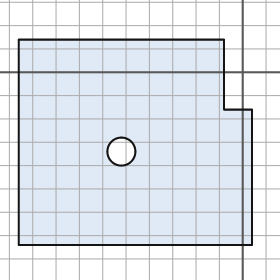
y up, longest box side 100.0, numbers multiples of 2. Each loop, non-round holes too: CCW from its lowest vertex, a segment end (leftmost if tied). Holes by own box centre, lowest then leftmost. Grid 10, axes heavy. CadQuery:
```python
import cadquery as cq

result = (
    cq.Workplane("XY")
    .moveTo(-96.0, -74.0)
    .lineTo(4.0, -74.0)
    .lineTo(4.0, -16.0)
    .lineTo(-8.0, -16.0)
    .lineTo(-8.0, 14.0)
    .lineTo(-96.0, 14.0)
    .close()
    .moveTo(-52.0, -34.0)
    .circle(6.0)
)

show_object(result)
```